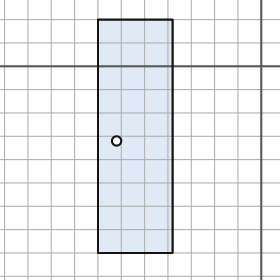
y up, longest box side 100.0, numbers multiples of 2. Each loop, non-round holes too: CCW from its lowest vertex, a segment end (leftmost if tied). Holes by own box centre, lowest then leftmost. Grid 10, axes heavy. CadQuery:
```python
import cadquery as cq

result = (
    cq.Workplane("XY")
    .moveTo(-70.0, -80.0)
    .lineTo(-38.0, -80.0)
    .lineTo(-38.0, 20.0)
    .lineTo(-70.0, 20.0)
    .close()
    .moveTo(-62.0, -32.0)
    .circle(2.0)
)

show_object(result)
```